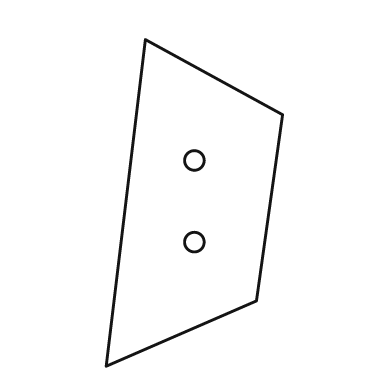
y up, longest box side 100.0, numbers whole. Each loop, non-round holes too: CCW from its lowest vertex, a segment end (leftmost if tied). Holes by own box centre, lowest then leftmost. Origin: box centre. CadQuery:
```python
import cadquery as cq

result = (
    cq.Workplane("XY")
    .moveTo(-27.0, -50.0)
    .lineTo(19.0, -30.0)
    .lineTo(27.0, 27.0)
    .lineTo(-15.0, 50.0)
    .close()
    .moveTo(0.0, -12.0)
    .circle(3.0)
    .moveTo(0.0, 13.0)
    .circle(3.0)
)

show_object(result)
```